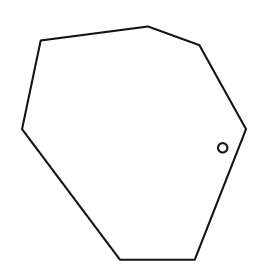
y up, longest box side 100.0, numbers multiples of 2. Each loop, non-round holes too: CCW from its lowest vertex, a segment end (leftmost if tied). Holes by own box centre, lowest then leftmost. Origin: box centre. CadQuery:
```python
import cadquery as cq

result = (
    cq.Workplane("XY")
    .moveTo(-6.0, -50.0)
    .lineTo(26.0, -50.0)
    .lineTo(48.0, 6.0)
    .lineTo(28.0, 42.0)
    .lineTo(6.0, 50.0)
    .lineTo(-40.0, 44.0)
    .lineTo(-48.0, 6.0)
    .close()
    .moveTo(38.0, -2.0)
    .circle(2.0)
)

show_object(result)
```